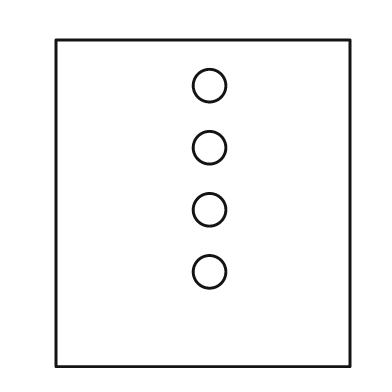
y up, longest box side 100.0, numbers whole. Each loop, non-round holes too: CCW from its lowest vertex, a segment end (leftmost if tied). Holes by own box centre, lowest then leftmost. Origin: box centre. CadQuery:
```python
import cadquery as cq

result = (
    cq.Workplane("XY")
    .moveTo(-45.0, -50.0)
    .lineTo(45.0, -50.0)
    .lineTo(45.0, 50.0)
    .lineTo(-45.0, 50.0)
    .close()
    .moveTo(2.0, -21.0)
    .circle(5.0)
    .moveTo(2.0, -2.0)
    .circle(5.0)
    .moveTo(2.0, 17.0)
    .circle(5.0)
    .moveTo(2.0, 36.0)
    .circle(5.0)
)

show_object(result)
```